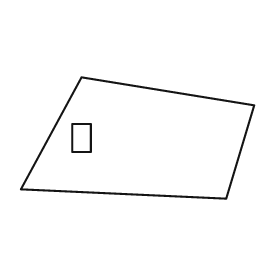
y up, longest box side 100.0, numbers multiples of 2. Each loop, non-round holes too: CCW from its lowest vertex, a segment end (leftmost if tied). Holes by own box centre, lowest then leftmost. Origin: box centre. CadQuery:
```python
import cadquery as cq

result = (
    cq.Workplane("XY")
    .moveTo(38.0, -26.0)
    .lineTo(50.0, 14.0)
    .lineTo(-24.0, 26.0)
    .lineTo(-50.0, -22.0)
    .close()
    .moveTo(-28.0, -6.0)
    .lineTo(-20.0, -6.0)
    .lineTo(-20.0, 6.0)
    .lineTo(-28.0, 6.0)
    .close()
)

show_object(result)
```